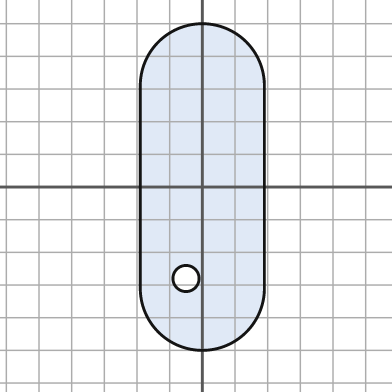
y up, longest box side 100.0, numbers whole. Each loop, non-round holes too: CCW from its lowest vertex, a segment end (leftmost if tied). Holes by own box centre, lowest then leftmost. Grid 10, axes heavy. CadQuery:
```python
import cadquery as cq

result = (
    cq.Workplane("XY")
    .moveTo(-19.0, -31.0)
    .threePointArc((0.0, -50.0), (19.0, -31.0))
    .lineTo(19.0, 31.0)
    .threePointArc((0.0, 50.0), (-19.0, 31.0))
    .close()
    .moveTo(-5.0, -28.0)
    .circle(4.0)
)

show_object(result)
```